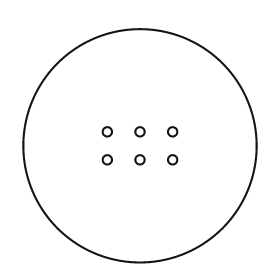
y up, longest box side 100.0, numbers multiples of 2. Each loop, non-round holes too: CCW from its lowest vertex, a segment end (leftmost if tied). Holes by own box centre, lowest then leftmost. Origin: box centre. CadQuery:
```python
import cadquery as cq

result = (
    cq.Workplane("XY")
    .moveTo(0.0, 0.0)
    .circle(50.0)
    .moveTo(-14.0, -6.0)
    .circle(2.0)
    .moveTo(0.0, -6.0)
    .circle(2.0)
    .moveTo(14.0, -6.0)
    .circle(2.0)
    .moveTo(-14.0, 6.0)
    .circle(2.0)
    .moveTo(0.0, 6.0)
    .circle(2.0)
    .moveTo(14.0, 6.0)
    .circle(2.0)
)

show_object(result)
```